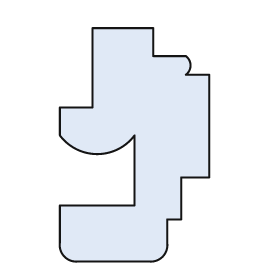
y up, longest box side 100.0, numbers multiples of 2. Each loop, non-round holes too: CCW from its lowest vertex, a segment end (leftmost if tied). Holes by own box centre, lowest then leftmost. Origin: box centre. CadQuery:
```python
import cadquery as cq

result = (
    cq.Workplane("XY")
    .moveTo(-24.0, -50.0)
    .lineTo(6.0, -50.0)
    .threePointArc((12.0, -48.0), (14.0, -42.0))
    .lineTo(14.0, -32.0)
    .lineTo(20.0, -32.0)
    .lineTo(20.0, -14.0)
    .lineTo(32.0, -14.0)
    .lineTo(32.0, 30.0)
    .lineTo(22.0, 30.0)
    .threePointArc((24.0, 34.0), (22.0, 38.0))
    .lineTo(8.0, 38.0)
    .lineTo(8.0, 50.0)
    .lineTo(-18.0, 50.0)
    .lineTo(-18.0, 16.0)
    .lineTo(-32.0, 16.0)
    .lineTo(-32.0, 4.0)
    .threePointArc((-16.0, -4.0), (0.0, 4.0))
    .lineTo(0.0, -26.0)
    .lineTo(-32.0, -26.0)
    .lineTo(-32.0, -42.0)
    .threePointArc((-30.0, -48.0), (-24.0, -50.0))
    .close()
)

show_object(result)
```